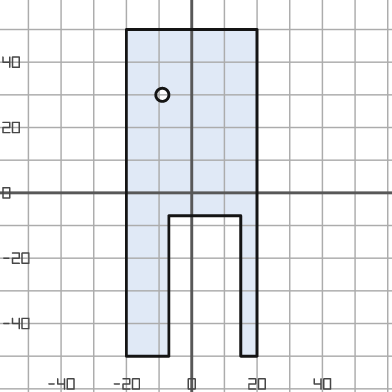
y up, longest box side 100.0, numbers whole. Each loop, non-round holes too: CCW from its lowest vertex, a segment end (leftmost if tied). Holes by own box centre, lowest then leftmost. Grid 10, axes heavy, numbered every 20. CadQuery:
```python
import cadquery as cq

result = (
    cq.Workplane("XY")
    .moveTo(-20.0, -50.0)
    .lineTo(-7.0, -50.0)
    .lineTo(-7.0, -7.0)
    .lineTo(15.0, -7.0)
    .lineTo(15.0, -50.0)
    .lineTo(20.0, -50.0)
    .lineTo(20.0, 50.0)
    .lineTo(-20.0, 50.0)
    .close()
    .moveTo(-9.0, 30.0)
    .circle(2.0)
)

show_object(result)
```